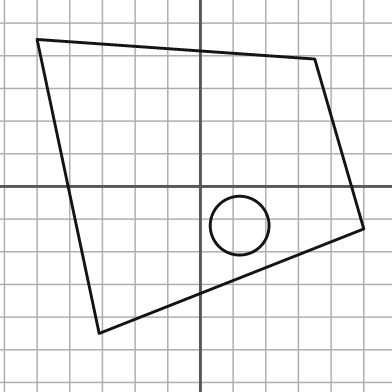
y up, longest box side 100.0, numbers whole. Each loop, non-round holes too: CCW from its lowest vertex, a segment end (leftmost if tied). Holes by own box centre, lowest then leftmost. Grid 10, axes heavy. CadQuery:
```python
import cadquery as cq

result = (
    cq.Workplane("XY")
    .moveTo(-31.0, -45.0)
    .lineTo(50.0, -13.0)
    .lineTo(35.0, 39.0)
    .lineTo(-50.0, 45.0)
    .close()
    .moveTo(12.0, -12.0)
    .circle(9.0)
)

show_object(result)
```